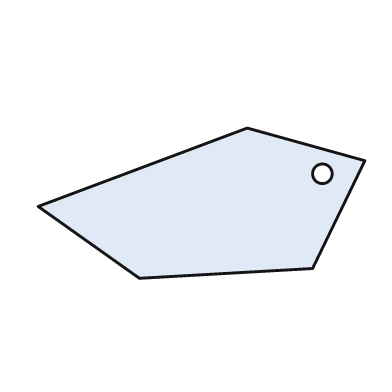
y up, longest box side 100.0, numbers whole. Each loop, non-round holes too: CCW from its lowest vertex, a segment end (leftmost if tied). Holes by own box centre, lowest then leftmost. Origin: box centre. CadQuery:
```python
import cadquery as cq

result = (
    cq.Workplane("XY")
    .moveTo(-19.0, -23.0)
    .lineTo(34.0, -20.0)
    .lineTo(50.0, 13.0)
    .lineTo(14.0, 23.0)
    .lineTo(-50.0, -1.0)
    .close()
    .moveTo(37.0, 9.0)
    .circle(3.0)
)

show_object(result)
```